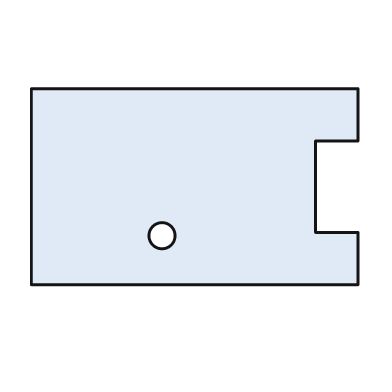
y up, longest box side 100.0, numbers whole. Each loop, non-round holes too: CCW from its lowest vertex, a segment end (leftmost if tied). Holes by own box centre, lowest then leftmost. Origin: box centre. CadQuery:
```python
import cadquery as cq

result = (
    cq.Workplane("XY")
    .moveTo(-50.0, -30.0)
    .lineTo(50.0, -30.0)
    .lineTo(50.0, -14.0)
    .lineTo(37.0, -14.0)
    .lineTo(37.0, 14.0)
    .lineTo(50.0, 14.0)
    .lineTo(50.0, 30.0)
    .lineTo(-50.0, 30.0)
    .close()
    .moveTo(-10.0, -15.0)
    .circle(4.0)
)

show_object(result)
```